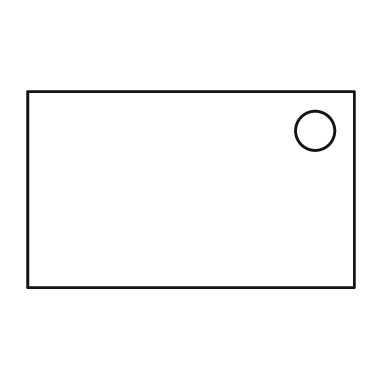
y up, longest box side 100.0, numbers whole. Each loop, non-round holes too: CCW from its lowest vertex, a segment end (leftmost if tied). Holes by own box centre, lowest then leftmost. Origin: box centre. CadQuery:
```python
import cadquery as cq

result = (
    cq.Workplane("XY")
    .moveTo(-50.0, -30.0)
    .lineTo(50.0, -30.0)
    .lineTo(50.0, 30.0)
    .lineTo(-50.0, 30.0)
    .close()
    .moveTo(38.0, 18.0)
    .circle(6.0)
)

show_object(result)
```